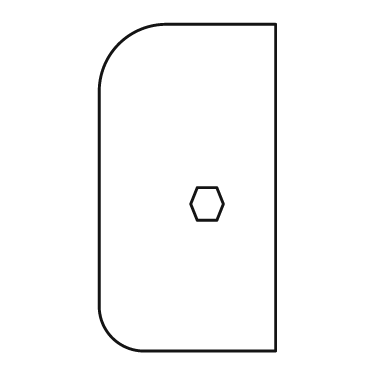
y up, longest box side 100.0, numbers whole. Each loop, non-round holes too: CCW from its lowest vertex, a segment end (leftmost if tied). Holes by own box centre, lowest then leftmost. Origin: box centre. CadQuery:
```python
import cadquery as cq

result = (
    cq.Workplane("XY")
    .moveTo(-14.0, -50.0)
    .lineTo(27.0, -50.0)
    .lineTo(27.0, 50.0)
    .lineTo(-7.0, 50.0)
    .threePointArc((-21.0, 44.0), (-27.0, 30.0))
    .lineTo(-27.0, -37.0)
    .threePointArc((-23.0, -46.0), (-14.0, -50.0))
    .close()
    .moveTo(3.0, -10.0)
    .lineTo(9.0, -10.0)
    .lineTo(11.0, -5.0)
    .lineTo(9.0, 0.0)
    .lineTo(3.0, 0.0)
    .lineTo(1.0, -5.0)
    .close()
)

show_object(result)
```